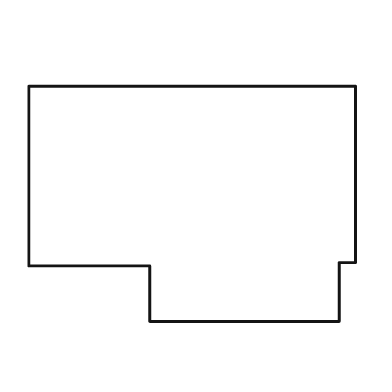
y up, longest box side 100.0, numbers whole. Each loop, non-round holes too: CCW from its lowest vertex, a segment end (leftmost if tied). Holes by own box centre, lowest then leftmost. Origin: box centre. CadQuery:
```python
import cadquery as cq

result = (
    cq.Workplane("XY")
    .moveTo(-13.0, -36.0)
    .lineTo(45.0, -36.0)
    .lineTo(45.0, -18.0)
    .lineTo(50.0, -18.0)
    .lineTo(50.0, 36.0)
    .lineTo(-50.0, 36.0)
    .lineTo(-50.0, -19.0)
    .lineTo(-13.0, -19.0)
    .close()
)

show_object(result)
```